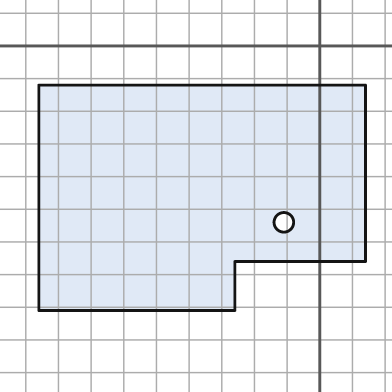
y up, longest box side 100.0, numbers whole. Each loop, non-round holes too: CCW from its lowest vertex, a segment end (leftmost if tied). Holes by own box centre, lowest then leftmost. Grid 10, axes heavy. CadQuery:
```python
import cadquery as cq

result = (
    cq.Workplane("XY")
    .moveTo(-86.0, -81.0)
    .lineTo(-26.0, -81.0)
    .lineTo(-26.0, -66.0)
    .lineTo(14.0, -66.0)
    .lineTo(14.0, -12.0)
    .lineTo(-86.0, -12.0)
    .close()
    .moveTo(-11.0, -54.0)
    .circle(3.0)
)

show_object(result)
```